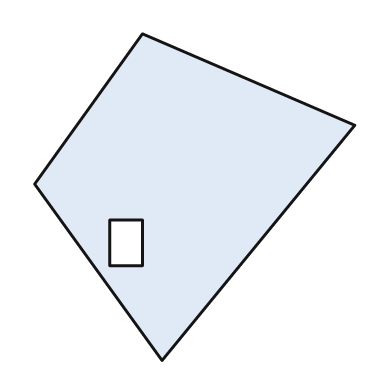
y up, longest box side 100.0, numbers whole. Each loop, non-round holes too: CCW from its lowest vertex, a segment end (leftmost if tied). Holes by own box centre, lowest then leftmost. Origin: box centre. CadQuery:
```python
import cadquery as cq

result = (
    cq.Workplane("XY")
    .moveTo(-10.0, -50.0)
    .lineTo(49.0, 22.0)
    .lineTo(-16.0, 50.0)
    .lineTo(-49.0, 4.0)
    .close()
    .moveTo(-26.0, -21.0)
    .lineTo(-16.0, -21.0)
    .lineTo(-16.0, -7.0)
    .lineTo(-26.0, -7.0)
    .close()
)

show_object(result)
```